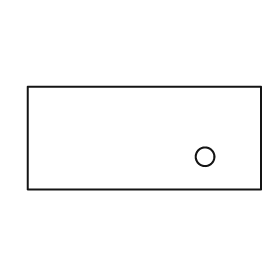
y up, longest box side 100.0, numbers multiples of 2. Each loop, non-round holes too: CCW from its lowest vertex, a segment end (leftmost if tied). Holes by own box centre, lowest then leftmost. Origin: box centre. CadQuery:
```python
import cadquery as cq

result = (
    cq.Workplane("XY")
    .moveTo(-50.0, -22.0)
    .lineTo(50.0, -22.0)
    .lineTo(50.0, 22.0)
    .lineTo(-50.0, 22.0)
    .close()
    .moveTo(26.0, -8.0)
    .circle(4.0)
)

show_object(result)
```